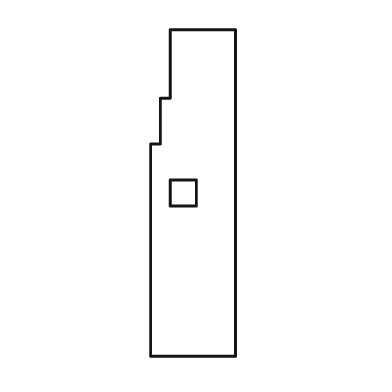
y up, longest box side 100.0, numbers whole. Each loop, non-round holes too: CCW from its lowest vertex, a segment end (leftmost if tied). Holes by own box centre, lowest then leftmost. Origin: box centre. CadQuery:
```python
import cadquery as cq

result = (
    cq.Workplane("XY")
    .moveTo(-13.0, -50.0)
    .lineTo(13.0, -50.0)
    .lineTo(13.0, 50.0)
    .lineTo(-7.0, 50.0)
    .lineTo(-7.0, 29.0)
    .lineTo(-10.0, 29.0)
    .lineTo(-10.0, 15.0)
    .lineTo(-13.0, 15.0)
    .close()
    .moveTo(-7.0, -4.0)
    .lineTo(1.0, -4.0)
    .lineTo(1.0, 4.0)
    .lineTo(-7.0, 4.0)
    .close()
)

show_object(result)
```